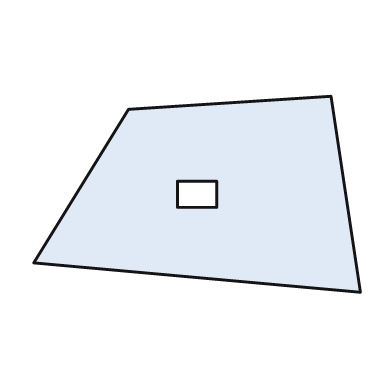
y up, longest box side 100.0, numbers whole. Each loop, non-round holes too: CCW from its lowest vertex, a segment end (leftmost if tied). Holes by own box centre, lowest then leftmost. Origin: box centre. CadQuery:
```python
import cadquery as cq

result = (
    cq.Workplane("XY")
    .moveTo(50.0, -30.0)
    .lineTo(41.0, 30.0)
    .lineTo(-21.0, 26.0)
    .lineTo(-50.0, -21.0)
    .close()
    .moveTo(-6.0, -4.0)
    .lineTo(6.0, -4.0)
    .lineTo(6.0, 4.0)
    .lineTo(-6.0, 4.0)
    .close()
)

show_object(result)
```